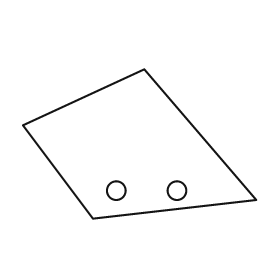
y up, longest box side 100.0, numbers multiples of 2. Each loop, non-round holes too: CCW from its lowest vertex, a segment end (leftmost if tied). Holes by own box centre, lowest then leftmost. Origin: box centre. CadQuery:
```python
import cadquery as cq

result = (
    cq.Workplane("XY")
    .moveTo(-20.0, -32.0)
    .lineTo(50.0, -24.0)
    .lineTo(2.0, 32.0)
    .lineTo(-50.0, 8.0)
    .close()
    .moveTo(-10.0, -20.0)
    .circle(4.0)
    .moveTo(16.0, -20.0)
    .circle(4.0)
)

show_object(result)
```